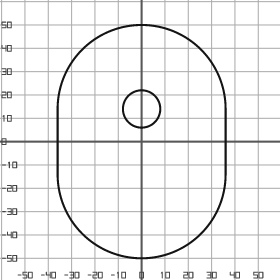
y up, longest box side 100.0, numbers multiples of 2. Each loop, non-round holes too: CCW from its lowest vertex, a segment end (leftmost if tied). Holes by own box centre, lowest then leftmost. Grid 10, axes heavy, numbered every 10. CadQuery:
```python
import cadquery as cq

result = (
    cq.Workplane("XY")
    .moveTo(-36.0, -14.0)
    .threePointArc((0.0, -50.0), (36.0, -14.0))
    .lineTo(36.0, 14.0)
    .threePointArc((0.0, 50.0), (-36.0, 14.0))
    .close()
    .moveTo(0.0, 14.0)
    .circle(8.0)
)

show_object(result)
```